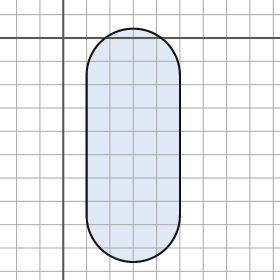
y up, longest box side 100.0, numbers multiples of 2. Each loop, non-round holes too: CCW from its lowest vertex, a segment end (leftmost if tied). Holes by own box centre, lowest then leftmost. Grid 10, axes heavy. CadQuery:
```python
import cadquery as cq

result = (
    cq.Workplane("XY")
    .moveTo(10.0, -76.0)
    .threePointArc((30.0, -96.0), (50.0, -76.0))
    .lineTo(50.0, -16.0)
    .threePointArc((30.0, 4.0), (10.0, -16.0))
    .close()
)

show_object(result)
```